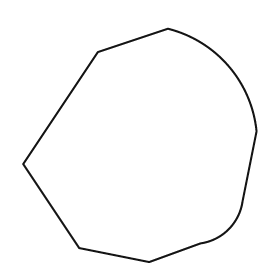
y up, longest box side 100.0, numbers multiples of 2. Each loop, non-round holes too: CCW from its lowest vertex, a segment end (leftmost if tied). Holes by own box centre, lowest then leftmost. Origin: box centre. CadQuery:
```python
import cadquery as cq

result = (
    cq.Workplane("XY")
    .moveTo(4.0, -50.0)
    .lineTo(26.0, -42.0)
    .threePointArc((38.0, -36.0), (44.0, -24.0))
    .lineTo(50.0, 6.0)
    .threePointArc((38.0, 34.0), (12.0, 50.0))
    .lineTo(-18.0, 40.0)
    .lineTo(-50.0, -8.0)
    .lineTo(-26.0, -44.0)
    .close()
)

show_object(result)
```